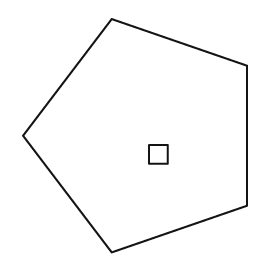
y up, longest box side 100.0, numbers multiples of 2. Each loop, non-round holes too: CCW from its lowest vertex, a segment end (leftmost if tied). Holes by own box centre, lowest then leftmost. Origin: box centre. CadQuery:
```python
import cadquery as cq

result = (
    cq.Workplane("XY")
    .moveTo(-10.0, -50.0)
    .lineTo(48.0, -30.0)
    .lineTo(48.0, 30.0)
    .lineTo(-10.0, 50.0)
    .lineTo(-48.0, 0.0)
    .close()
    .moveTo(6.0, -12.0)
    .lineTo(14.0, -12.0)
    .lineTo(14.0, -4.0)
    .lineTo(6.0, -4.0)
    .close()
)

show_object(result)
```